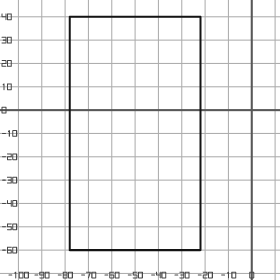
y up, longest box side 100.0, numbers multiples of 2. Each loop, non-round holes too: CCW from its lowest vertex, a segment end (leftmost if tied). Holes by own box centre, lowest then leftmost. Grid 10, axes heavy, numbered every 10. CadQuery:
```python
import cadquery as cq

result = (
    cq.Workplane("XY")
    .moveTo(-78.0, -60.0)
    .lineTo(-22.0, -60.0)
    .lineTo(-22.0, 40.0)
    .lineTo(-78.0, 40.0)
    .close()
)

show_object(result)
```